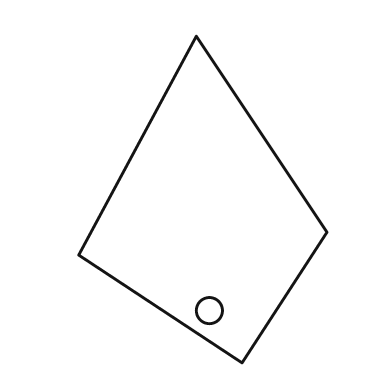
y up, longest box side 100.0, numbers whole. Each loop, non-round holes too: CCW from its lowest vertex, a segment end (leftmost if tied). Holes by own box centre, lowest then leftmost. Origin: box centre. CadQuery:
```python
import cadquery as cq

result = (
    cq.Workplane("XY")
    .moveTo(12.0, -50.0)
    .lineTo(38.0, -10.0)
    .lineTo(-2.0, 50.0)
    .lineTo(-38.0, -17.0)
    .close()
    .moveTo(2.0, -34.0)
    .circle(4.0)
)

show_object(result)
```